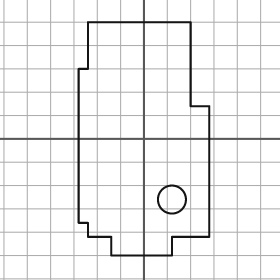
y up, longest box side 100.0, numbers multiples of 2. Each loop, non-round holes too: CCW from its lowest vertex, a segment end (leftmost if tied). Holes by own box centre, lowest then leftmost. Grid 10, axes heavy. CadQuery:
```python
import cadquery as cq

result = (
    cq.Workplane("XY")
    .moveTo(-14.0, -50.0)
    .lineTo(12.0, -50.0)
    .lineTo(12.0, -42.0)
    .lineTo(28.0, -42.0)
    .lineTo(28.0, 14.0)
    .lineTo(20.0, 14.0)
    .lineTo(20.0, 50.0)
    .lineTo(-24.0, 50.0)
    .lineTo(-24.0, 30.0)
    .lineTo(-28.0, 30.0)
    .lineTo(-28.0, -36.0)
    .lineTo(-24.0, -36.0)
    .lineTo(-24.0, -42.0)
    .lineTo(-14.0, -42.0)
    .close()
    .moveTo(12.0, -26.0)
    .circle(6.0)
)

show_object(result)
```